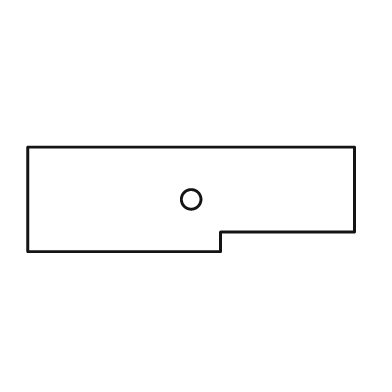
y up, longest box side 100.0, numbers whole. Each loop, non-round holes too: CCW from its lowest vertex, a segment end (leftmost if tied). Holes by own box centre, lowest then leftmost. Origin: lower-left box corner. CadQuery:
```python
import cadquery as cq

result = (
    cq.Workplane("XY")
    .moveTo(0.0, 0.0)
    .lineTo(59.0, 0.0)
    .lineTo(59.0, 6.0)
    .lineTo(100.0, 6.0)
    .lineTo(100.0, 32.0)
    .lineTo(0.0, 32.0)
    .close()
    .moveTo(50.0, 16.0)
    .circle(3.0)
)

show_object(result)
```